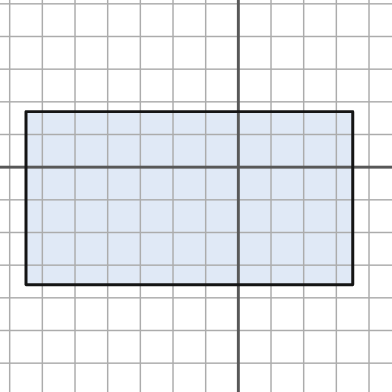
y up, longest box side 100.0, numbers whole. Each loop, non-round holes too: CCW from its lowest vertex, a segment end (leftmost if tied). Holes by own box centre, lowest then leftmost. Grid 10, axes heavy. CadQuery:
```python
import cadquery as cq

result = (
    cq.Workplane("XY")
    .moveTo(-65.0, -36.0)
    .lineTo(35.0, -36.0)
    .lineTo(35.0, 17.0)
    .lineTo(-65.0, 17.0)
    .close()
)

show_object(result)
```